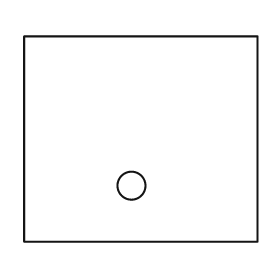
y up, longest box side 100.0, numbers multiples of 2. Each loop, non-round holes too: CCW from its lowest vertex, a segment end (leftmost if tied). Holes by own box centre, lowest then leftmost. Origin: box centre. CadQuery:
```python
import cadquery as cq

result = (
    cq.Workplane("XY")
    .moveTo(-50.0, -44.0)
    .lineTo(50.0, -44.0)
    .lineTo(50.0, 44.0)
    .lineTo(-50.0, 44.0)
    .close()
    .moveTo(-4.0, -20.0)
    .circle(6.0)
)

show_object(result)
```